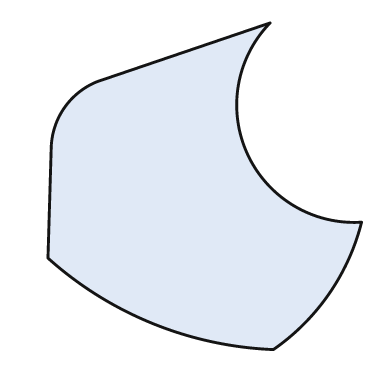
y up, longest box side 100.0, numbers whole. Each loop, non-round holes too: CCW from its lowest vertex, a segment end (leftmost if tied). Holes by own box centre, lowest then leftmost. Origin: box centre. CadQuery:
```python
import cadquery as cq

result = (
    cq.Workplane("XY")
    .moveTo(21.0, -50.0)
    .threePointArc((38.0, -33.0), (48.0, -11.0))
    .threePointArc((13.0, 10.0), (20.0, 50.0))
    .lineTo(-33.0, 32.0)
    .threePointArc((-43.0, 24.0), (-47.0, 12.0))
    .lineTo(-48.0, -22.0)
    .threePointArc((-16.0, -42.0), (21.0, -50.0))
    .close()
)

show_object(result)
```